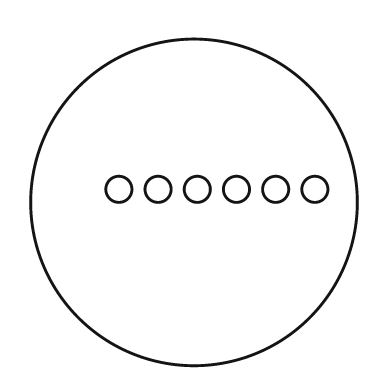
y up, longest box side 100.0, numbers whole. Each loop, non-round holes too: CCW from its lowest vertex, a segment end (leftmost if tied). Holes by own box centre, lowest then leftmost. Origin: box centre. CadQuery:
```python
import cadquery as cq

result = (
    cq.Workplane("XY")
    .moveTo(0.0, 0.0)
    .circle(50.0)
    .moveTo(-23.0, 4.0)
    .circle(4.0)
    .moveTo(-11.0, 4.0)
    .circle(4.0)
    .moveTo(1.0, 4.0)
    .circle(4.0)
    .moveTo(13.0, 4.0)
    .circle(4.0)
    .moveTo(25.0, 4.0)
    .circle(4.0)
    .moveTo(37.0, 4.0)
    .circle(4.0)
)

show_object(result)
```